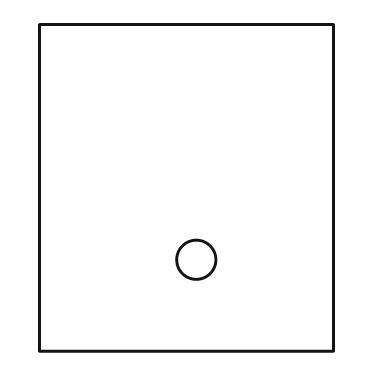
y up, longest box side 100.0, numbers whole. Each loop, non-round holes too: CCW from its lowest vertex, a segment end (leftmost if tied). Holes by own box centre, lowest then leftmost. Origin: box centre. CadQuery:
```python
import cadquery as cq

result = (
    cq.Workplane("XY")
    .moveTo(-45.0, -50.0)
    .lineTo(45.0, -50.0)
    .lineTo(45.0, 50.0)
    .lineTo(-45.0, 50.0)
    .close()
    .moveTo(3.0, -22.0)
    .circle(6.0)
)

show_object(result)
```